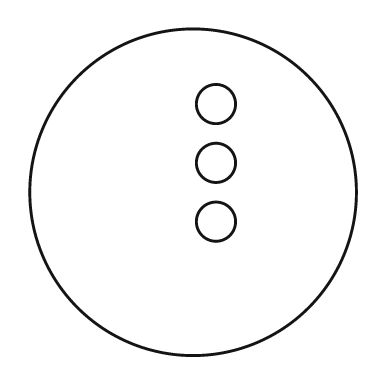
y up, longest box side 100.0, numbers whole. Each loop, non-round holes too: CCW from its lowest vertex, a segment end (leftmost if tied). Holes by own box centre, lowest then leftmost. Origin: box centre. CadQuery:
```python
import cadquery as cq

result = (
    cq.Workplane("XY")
    .moveTo(0.0, 0.0)
    .circle(50.0)
    .moveTo(7.0, -9.0)
    .circle(6.0)
    .moveTo(7.0, 9.0)
    .circle(6.0)
    .moveTo(7.0, 27.0)
    .circle(6.0)
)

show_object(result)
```